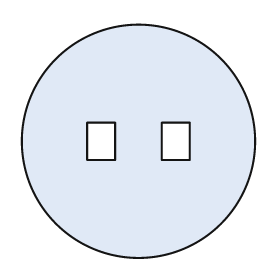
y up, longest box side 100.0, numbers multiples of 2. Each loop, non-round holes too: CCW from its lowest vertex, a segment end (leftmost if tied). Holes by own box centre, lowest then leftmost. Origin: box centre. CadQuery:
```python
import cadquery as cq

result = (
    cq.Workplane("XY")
    .moveTo(0.0, 0.0)
    .circle(50.0)
    .moveTo(-22.0, -8.0)
    .lineTo(-10.0, -8.0)
    .lineTo(-10.0, 8.0)
    .lineTo(-22.0, 8.0)
    .close()
    .moveTo(10.0, -8.0)
    .lineTo(22.0, -8.0)
    .lineTo(22.0, 8.0)
    .lineTo(10.0, 8.0)
    .close()
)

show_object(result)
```